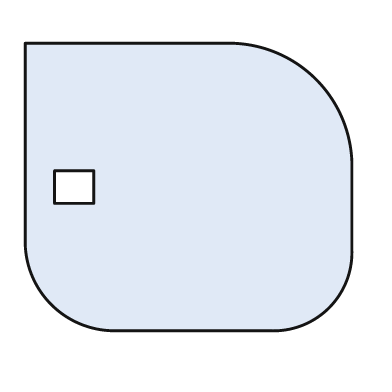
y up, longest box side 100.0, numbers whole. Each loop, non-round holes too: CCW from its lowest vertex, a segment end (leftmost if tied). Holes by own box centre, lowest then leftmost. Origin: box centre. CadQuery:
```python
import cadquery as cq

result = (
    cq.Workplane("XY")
    .moveTo(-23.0, -44.0)
    .lineTo(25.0, -44.0)
    .threePointArc((43.0, -37.0), (50.0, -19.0))
    .lineTo(50.0, 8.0)
    .threePointArc((39.0, 33.0), (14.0, 44.0))
    .lineTo(-50.0, 44.0)
    .lineTo(-50.0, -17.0)
    .threePointArc((-42.0, -36.0), (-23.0, -44.0))
    .close()
    .moveTo(-41.0, -5.0)
    .lineTo(-29.0, -5.0)
    .lineTo(-29.0, 5.0)
    .lineTo(-41.0, 5.0)
    .close()
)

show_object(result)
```